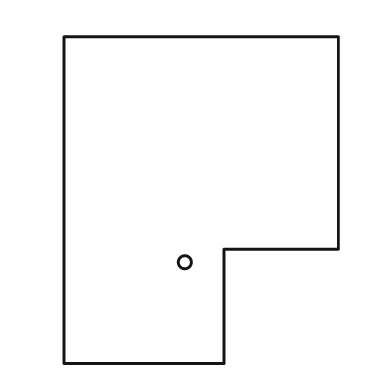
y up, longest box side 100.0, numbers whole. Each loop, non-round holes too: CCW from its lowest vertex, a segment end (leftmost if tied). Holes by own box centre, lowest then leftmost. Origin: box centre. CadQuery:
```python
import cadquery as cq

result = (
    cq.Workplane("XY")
    .moveTo(-42.0, -50.0)
    .lineTo(7.0, -50.0)
    .lineTo(7.0, -15.0)
    .lineTo(42.0, -15.0)
    .lineTo(42.0, 50.0)
    .lineTo(-42.0, 50.0)
    .close()
    .moveTo(-5.0, -19.0)
    .circle(2.0)
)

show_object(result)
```